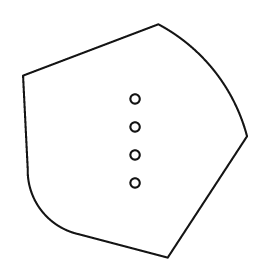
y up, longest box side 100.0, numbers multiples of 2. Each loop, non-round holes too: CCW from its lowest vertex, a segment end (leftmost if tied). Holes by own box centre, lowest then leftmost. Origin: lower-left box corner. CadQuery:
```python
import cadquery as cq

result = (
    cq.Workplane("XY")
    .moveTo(62.0, 0.0)
    .lineTo(96.0, 52.0)
    .threePointArc((82.0, 80.0), (58.0, 100.0))
    .lineTo(0.0, 78.0)
    .lineTo(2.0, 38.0)
    .threePointArc((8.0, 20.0), (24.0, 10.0))
    .close()
    .moveTo(48.0, 32.0)
    .circle(2.0)
    .moveTo(48.0, 44.0)
    .circle(2.0)
    .moveTo(48.0, 56.0)
    .circle(2.0)
    .moveTo(48.0, 68.0)
    .circle(2.0)
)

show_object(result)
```